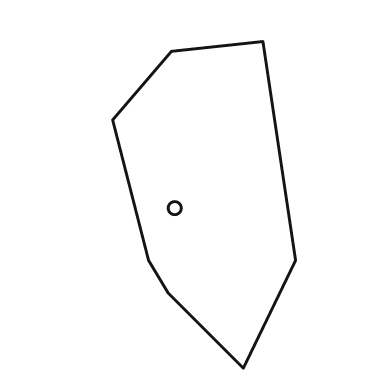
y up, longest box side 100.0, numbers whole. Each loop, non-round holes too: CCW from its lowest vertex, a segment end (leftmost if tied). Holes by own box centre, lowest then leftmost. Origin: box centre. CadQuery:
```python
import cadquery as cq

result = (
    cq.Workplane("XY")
    .moveTo(12.0, -50.0)
    .lineTo(28.0, -17.0)
    .lineTo(18.0, 50.0)
    .lineTo(-10.0, 47.0)
    .lineTo(-28.0, 26.0)
    .lineTo(-17.0, -17.0)
    .lineTo(-11.0, -27.0)
    .close()
    .moveTo(-9.0, -1.0)
    .circle(2.0)
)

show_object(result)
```